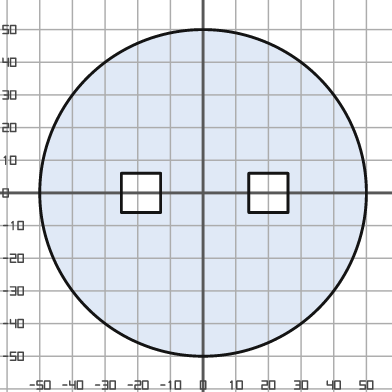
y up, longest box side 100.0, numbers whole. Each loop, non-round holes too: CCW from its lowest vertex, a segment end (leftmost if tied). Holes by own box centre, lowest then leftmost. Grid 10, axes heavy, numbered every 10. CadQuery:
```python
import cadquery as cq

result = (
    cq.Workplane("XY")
    .moveTo(0.0, 0.0)
    .circle(50.0)
    .moveTo(-25.0, -6.0)
    .lineTo(-13.0, -6.0)
    .lineTo(-13.0, 6.0)
    .lineTo(-25.0, 6.0)
    .close()
    .moveTo(14.0, -6.0)
    .lineTo(26.0, -6.0)
    .lineTo(26.0, 6.0)
    .lineTo(14.0, 6.0)
    .close()
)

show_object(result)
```